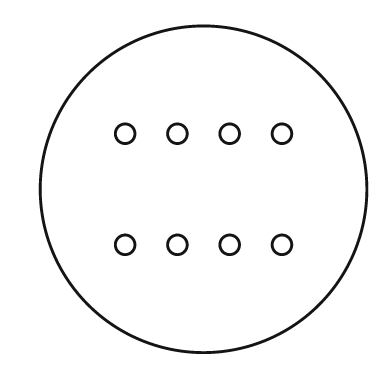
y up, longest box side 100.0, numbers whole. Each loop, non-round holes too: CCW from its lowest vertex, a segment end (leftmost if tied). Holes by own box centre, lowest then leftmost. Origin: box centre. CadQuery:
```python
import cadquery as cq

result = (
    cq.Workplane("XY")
    .moveTo(0.0, 0.0)
    .circle(50.0)
    .moveTo(-24.0, -17.0)
    .circle(3.0)
    .moveTo(-8.0, -17.0)
    .circle(3.0)
    .moveTo(8.0, -17.0)
    .circle(3.0)
    .moveTo(24.0, -17.0)
    .circle(3.0)
    .moveTo(-24.0, 17.0)
    .circle(3.0)
    .moveTo(-8.0, 17.0)
    .circle(3.0)
    .moveTo(8.0, 17.0)
    .circle(3.0)
    .moveTo(24.0, 17.0)
    .circle(3.0)
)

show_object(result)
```